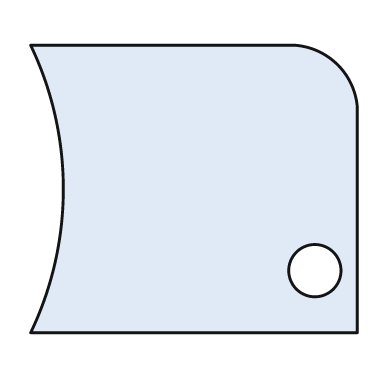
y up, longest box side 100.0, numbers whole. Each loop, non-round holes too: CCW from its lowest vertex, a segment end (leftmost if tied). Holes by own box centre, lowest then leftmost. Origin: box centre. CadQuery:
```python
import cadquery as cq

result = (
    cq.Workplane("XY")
    .moveTo(-50.0, -44.0)
    .lineTo(50.0, -44.0)
    .lineTo(50.0, 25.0)
    .threePointArc((44.0, 38.0), (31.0, 44.0))
    .lineTo(-50.0, 44.0)
    .threePointArc((-40.0, 0.0), (-50.0, -44.0))
    .close()
    .moveTo(37.0, -25.0)
    .circle(8.0)
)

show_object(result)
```